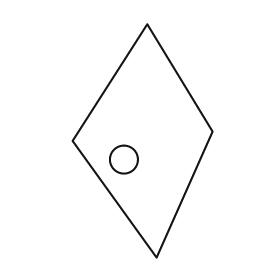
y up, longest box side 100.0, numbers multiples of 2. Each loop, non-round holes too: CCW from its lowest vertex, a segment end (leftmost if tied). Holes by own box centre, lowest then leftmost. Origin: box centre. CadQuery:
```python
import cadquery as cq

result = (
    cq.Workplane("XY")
    .moveTo(6.0, -50.0)
    .lineTo(30.0, 4.0)
    .lineTo(2.0, 50.0)
    .lineTo(-30.0, 0.0)
    .close()
    .moveTo(-8.0, -8.0)
    .circle(6.0)
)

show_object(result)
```